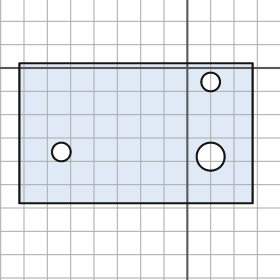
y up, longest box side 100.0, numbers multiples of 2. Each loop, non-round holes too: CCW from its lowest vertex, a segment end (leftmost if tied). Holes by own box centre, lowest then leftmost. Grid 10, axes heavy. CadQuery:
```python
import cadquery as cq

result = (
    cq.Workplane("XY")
    .moveTo(-72.0, -58.0)
    .lineTo(28.0, -58.0)
    .lineTo(28.0, 2.0)
    .lineTo(-72.0, 2.0)
    .close()
    .moveTo(10.0, -38.0)
    .circle(6.0)
    .moveTo(-54.0, -36.0)
    .circle(4.0)
    .moveTo(10.0, -6.0)
    .circle(4.0)
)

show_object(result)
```